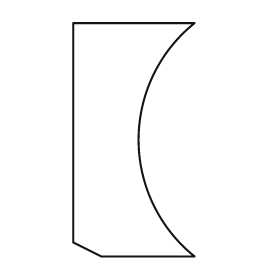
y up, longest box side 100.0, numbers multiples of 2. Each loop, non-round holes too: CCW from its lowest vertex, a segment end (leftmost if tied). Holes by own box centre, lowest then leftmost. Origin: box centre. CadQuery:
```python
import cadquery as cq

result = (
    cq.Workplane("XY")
    .moveTo(-14.0, -50.0)
    .lineTo(26.0, -50.0)
    .threePointArc((2.0, 0.0), (26.0, 50.0))
    .lineTo(-26.0, 50.0)
    .lineTo(-26.0, -44.0)
    .close()
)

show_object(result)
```